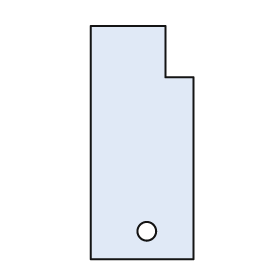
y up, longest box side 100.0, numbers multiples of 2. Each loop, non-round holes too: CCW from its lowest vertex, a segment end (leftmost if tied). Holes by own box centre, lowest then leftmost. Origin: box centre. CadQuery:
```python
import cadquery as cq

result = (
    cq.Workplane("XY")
    .moveTo(-22.0, -50.0)
    .lineTo(22.0, -50.0)
    .lineTo(22.0, 28.0)
    .lineTo(10.0, 28.0)
    .lineTo(10.0, 50.0)
    .lineTo(-22.0, 50.0)
    .close()
    .moveTo(2.0, -38.0)
    .circle(4.0)
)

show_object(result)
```